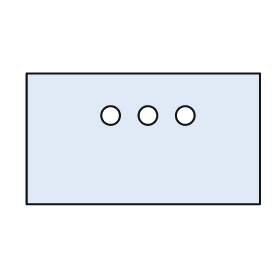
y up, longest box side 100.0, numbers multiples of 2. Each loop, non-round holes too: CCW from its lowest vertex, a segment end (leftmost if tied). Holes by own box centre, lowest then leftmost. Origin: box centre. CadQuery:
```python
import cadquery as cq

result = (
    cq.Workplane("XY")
    .moveTo(-50.0, -28.0)
    .lineTo(50.0, -28.0)
    .lineTo(50.0, 28.0)
    .lineTo(-50.0, 28.0)
    .close()
    .moveTo(-14.0, 10.0)
    .circle(4.0)
    .moveTo(2.0, 10.0)
    .circle(4.0)
    .moveTo(18.0, 10.0)
    .circle(4.0)
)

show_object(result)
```